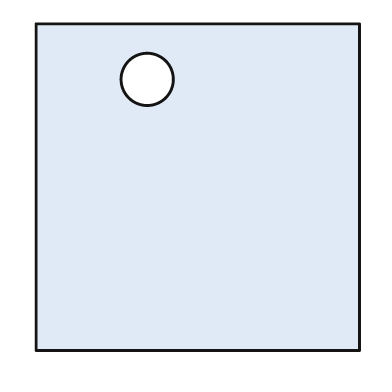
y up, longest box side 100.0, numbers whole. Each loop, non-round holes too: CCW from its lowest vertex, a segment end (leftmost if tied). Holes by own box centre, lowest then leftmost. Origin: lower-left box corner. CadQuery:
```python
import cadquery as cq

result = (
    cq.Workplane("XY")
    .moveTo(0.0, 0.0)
    .lineTo(99.0, 0.0)
    .lineTo(99.0, 100.0)
    .lineTo(0.0, 100.0)
    .close()
    .moveTo(34.0, 83.0)
    .circle(8.0)
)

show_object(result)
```